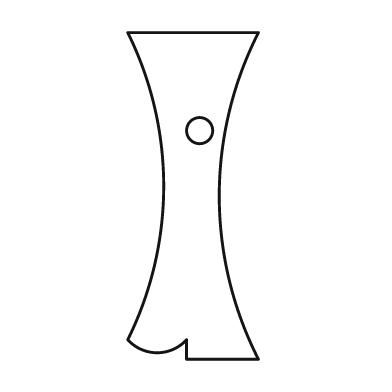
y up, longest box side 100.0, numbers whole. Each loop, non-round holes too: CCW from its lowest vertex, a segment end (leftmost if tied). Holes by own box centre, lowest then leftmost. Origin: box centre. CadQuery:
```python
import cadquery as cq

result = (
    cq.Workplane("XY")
    .moveTo(-2.0, -50.0)
    .lineTo(20.0, -50.0)
    .threePointArc((8.0, 0.0), (20.0, 50.0))
    .lineTo(-20.0, 50.0)
    .threePointArc((-9.0, 3.0), (-20.0, -44.0))
    .threePointArc((-11.0, -48.0), (-2.0, -44.0))
    .close()
    .moveTo(2.0, 20.0)
    .circle(4.0)
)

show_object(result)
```